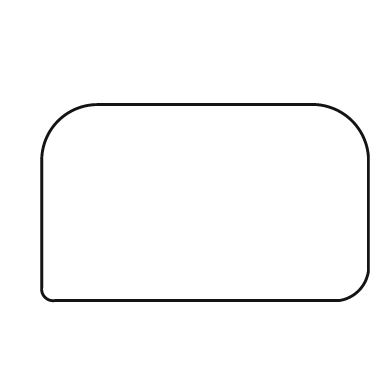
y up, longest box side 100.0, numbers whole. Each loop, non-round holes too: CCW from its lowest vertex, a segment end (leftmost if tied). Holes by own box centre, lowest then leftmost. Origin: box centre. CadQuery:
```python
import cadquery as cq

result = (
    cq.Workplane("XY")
    .moveTo(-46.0, -30.0)
    .lineTo(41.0, -30.0)
    .threePointArc((47.0, -27.0), (50.0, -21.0))
    .lineTo(50.0, 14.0)
    .threePointArc((45.0, 25.0), (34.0, 30.0))
    .lineTo(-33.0, 30.0)
    .threePointArc((-45.0, 25.0), (-50.0, 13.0))
    .lineTo(-50.0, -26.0)
    .threePointArc((-49.0, -29.0), (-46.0, -30.0))
    .close()
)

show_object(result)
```